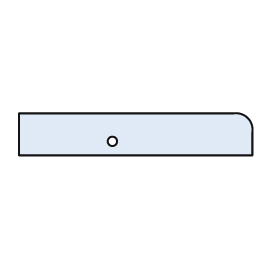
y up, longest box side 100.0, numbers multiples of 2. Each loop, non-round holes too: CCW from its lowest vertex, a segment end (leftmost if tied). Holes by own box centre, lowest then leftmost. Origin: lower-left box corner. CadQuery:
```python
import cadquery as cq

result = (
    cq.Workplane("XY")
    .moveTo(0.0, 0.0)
    .lineTo(100.0, 0.0)
    .lineTo(100.0, 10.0)
    .threePointArc((98.0, 16.0), (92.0, 18.0))
    .lineTo(0.0, 18.0)
    .close()
    .moveTo(40.0, 6.0)
    .circle(2.0)
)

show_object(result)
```